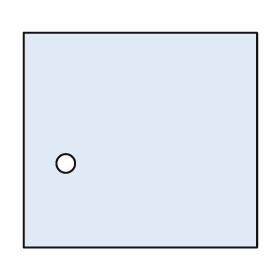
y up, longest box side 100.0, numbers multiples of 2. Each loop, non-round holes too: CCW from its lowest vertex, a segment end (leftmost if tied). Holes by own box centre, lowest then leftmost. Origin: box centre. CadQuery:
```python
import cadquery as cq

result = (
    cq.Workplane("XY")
    .moveTo(-50.0, -46.0)
    .lineTo(50.0, -46.0)
    .lineTo(50.0, 46.0)
    .lineTo(-50.0, 46.0)
    .close()
    .moveTo(-32.0, -10.0)
    .circle(4.0)
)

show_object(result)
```